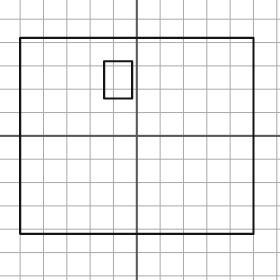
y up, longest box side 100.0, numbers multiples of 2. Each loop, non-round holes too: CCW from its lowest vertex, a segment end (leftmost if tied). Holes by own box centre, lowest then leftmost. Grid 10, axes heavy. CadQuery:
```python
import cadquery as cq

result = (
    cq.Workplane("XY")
    .moveTo(-50.0, -42.0)
    .lineTo(50.0, -42.0)
    .lineTo(50.0, 42.0)
    .lineTo(-50.0, 42.0)
    .close()
    .moveTo(-14.0, 16.0)
    .lineTo(-2.0, 16.0)
    .lineTo(-2.0, 32.0)
    .lineTo(-14.0, 32.0)
    .close()
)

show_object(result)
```